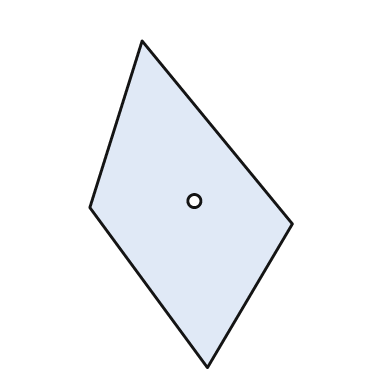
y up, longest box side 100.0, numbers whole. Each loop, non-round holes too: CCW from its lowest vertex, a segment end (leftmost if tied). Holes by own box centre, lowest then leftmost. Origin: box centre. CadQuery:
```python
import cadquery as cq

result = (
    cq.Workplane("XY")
    .moveTo(5.0, -50.0)
    .lineTo(31.0, -6.0)
    .lineTo(-15.0, 50.0)
    .lineTo(-31.0, -1.0)
    .close()
    .moveTo(1.0, 1.0)
    .circle(2.0)
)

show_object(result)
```